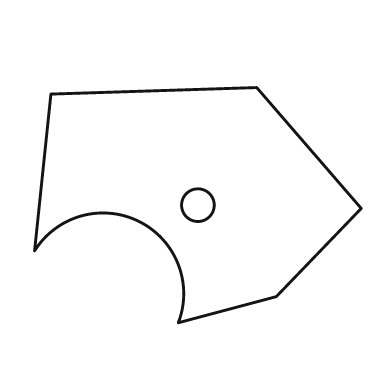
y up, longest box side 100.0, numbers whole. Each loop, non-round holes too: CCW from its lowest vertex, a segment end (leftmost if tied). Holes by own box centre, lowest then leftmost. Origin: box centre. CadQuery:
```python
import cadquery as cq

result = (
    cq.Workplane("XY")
    .moveTo(-6.0, -36.0)
    .lineTo(24.0, -28.0)
    .lineTo(50.0, -1.0)
    .lineTo(18.0, 36.0)
    .lineTo(-45.0, 34.0)
    .lineTo(-50.0, -14.0)
    .threePointArc((-18.0, -5.0), (-6.0, -36.0))
    .close()
    .moveTo(0.0, 0.0)
    .circle(5.0)
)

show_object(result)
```